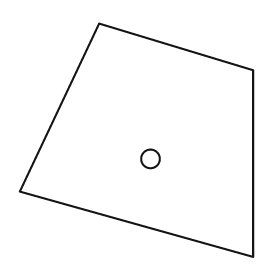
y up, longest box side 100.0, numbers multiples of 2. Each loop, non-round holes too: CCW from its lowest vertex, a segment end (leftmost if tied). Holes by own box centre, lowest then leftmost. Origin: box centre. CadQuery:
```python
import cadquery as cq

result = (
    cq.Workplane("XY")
    .moveTo(50.0, -50.0)
    .lineTo(50.0, 30.0)
    .lineTo(-16.0, 50.0)
    .lineTo(-50.0, -22.0)
    .close()
    .moveTo(6.0, -8.0)
    .circle(4.0)
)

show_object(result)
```